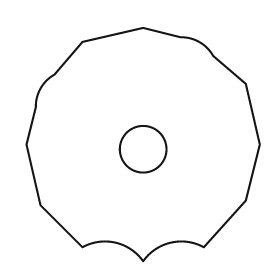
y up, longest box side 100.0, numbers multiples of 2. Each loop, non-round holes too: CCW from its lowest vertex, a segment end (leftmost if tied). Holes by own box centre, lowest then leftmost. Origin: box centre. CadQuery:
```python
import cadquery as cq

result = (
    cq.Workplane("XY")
    .moveTo(0.0, -50.0)
    .threePointArc((12.0, -42.0), (26.0, -44.0))
    .lineTo(44.0, -24.0)
    .lineTo(50.0, 0.0)
    .lineTo(44.0, 26.0)
    .lineTo(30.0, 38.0)
    .threePointArc((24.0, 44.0), (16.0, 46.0))
    .lineTo(0.0, 50.0)
    .lineTo(-26.0, 44.0)
    .lineTo(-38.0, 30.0)
    .threePointArc((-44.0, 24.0), (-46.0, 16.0))
    .lineTo(-50.0, 0.0)
    .lineTo(-44.0, -26.0)
    .lineTo(-26.0, -44.0)
    .threePointArc((-12.0, -42.0), (0.0, -50.0))
    .close()
    .moveTo(0.0, -2.0)
    .circle(10.0)
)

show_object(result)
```